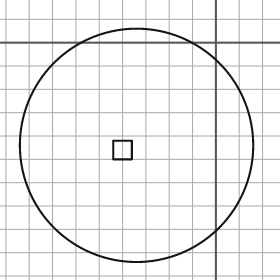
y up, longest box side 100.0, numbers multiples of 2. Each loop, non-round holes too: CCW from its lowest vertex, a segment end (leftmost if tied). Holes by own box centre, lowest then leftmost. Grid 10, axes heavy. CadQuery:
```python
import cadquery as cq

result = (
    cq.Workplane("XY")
    .moveTo(-34.0, -44.0)
    .circle(50.0)
    .moveTo(-44.0, -50.0)
    .lineTo(-36.0, -50.0)
    .lineTo(-36.0, -42.0)
    .lineTo(-44.0, -42.0)
    .close()
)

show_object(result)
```